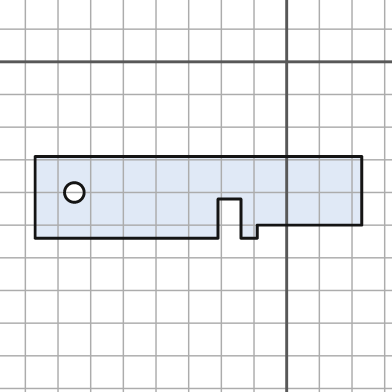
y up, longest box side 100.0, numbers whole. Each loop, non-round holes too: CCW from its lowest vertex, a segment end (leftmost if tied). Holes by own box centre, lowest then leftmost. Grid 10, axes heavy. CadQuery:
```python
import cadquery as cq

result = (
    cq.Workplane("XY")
    .moveTo(-77.0, -54.0)
    .lineTo(-21.0, -54.0)
    .lineTo(-21.0, -42.0)
    .lineTo(-14.0, -42.0)
    .lineTo(-14.0, -54.0)
    .lineTo(-9.0, -54.0)
    .lineTo(-9.0, -50.0)
    .lineTo(23.0, -50.0)
    .lineTo(23.0, -29.0)
    .lineTo(-77.0, -29.0)
    .close()
    .moveTo(-65.0, -40.0)
    .circle(3.0)
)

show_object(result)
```